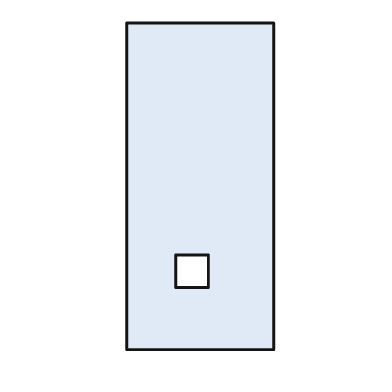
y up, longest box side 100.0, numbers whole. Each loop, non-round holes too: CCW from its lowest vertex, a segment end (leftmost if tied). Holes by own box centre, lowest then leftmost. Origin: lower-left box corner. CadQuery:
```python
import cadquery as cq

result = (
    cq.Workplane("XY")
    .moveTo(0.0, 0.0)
    .lineTo(45.0, 0.0)
    .lineTo(45.0, 100.0)
    .lineTo(0.0, 100.0)
    .close()
    .moveTo(15.0, 19.0)
    .lineTo(25.0, 19.0)
    .lineTo(25.0, 29.0)
    .lineTo(15.0, 29.0)
    .close()
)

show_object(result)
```